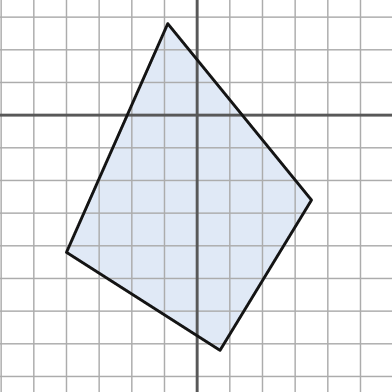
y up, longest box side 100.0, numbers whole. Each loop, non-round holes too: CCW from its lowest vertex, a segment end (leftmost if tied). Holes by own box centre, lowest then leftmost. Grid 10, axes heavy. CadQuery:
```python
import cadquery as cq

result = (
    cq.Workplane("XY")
    .moveTo(7.0, -72.0)
    .lineTo(35.0, -26.0)
    .lineTo(-9.0, 28.0)
    .lineTo(-40.0, -42.0)
    .close()
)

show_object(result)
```